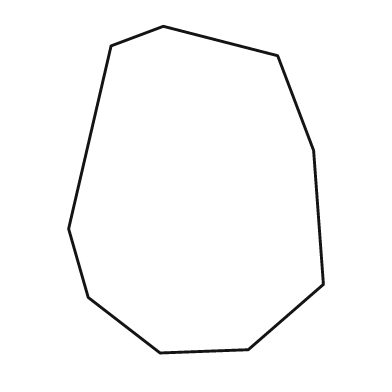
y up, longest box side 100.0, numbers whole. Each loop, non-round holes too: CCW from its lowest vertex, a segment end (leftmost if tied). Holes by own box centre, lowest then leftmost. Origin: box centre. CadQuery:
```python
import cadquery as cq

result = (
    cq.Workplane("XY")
    .moveTo(-11.0, -50.0)
    .lineTo(16.0, -49.0)
    .lineTo(39.0, -29.0)
    .lineTo(36.0, 12.0)
    .lineTo(25.0, 41.0)
    .lineTo(-10.0, 50.0)
    .lineTo(-26.0, 44.0)
    .lineTo(-39.0, -12.0)
    .lineTo(-33.0, -33.0)
    .close()
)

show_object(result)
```